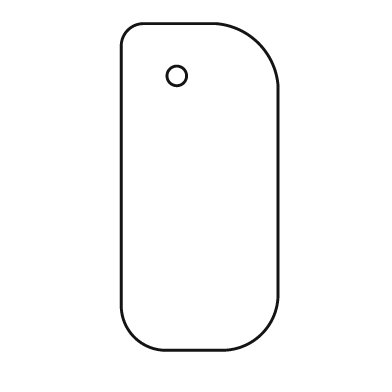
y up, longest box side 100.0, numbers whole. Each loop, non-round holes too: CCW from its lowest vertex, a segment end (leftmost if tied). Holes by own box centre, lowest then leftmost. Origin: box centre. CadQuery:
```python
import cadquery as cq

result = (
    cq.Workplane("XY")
    .moveTo(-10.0, -50.0)
    .lineTo(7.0, -50.0)
    .threePointArc((19.0, -45.0), (24.0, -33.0))
    .lineTo(24.0, 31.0)
    .threePointArc((18.0, 44.0), (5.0, 50.0))
    .lineTo(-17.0, 50.0)
    .threePointArc((-22.0, 48.0), (-24.0, 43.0))
    .lineTo(-24.0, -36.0)
    .threePointArc((-20.0, -46.0), (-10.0, -50.0))
    .close()
    .moveTo(-7.0, 34.0)
    .circle(3.0)
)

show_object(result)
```